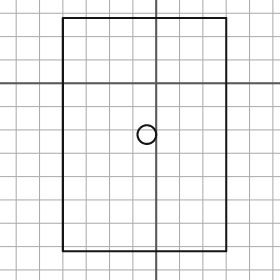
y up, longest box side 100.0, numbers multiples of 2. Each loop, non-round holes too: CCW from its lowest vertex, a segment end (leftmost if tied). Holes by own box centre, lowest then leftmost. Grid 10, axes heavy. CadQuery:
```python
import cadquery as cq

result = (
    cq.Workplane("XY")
    .moveTo(-40.0, -72.0)
    .lineTo(30.0, -72.0)
    .lineTo(30.0, 28.0)
    .lineTo(-40.0, 28.0)
    .close()
    .moveTo(-4.0, -22.0)
    .circle(4.0)
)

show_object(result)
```